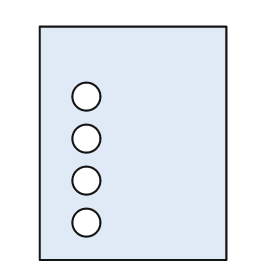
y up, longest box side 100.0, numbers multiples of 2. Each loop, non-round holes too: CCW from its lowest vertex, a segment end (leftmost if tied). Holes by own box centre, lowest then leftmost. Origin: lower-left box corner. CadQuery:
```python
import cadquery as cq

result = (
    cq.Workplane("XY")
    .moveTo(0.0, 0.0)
    .lineTo(80.0, 0.0)
    .lineTo(80.0, 100.0)
    .lineTo(0.0, 100.0)
    .close()
    .moveTo(20.0, 16.0)
    .circle(6.0)
    .moveTo(20.0, 34.0)
    .circle(6.0)
    .moveTo(20.0, 52.0)
    .circle(6.0)
    .moveTo(20.0, 70.0)
    .circle(6.0)
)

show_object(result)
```